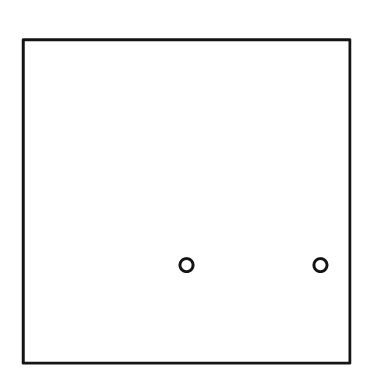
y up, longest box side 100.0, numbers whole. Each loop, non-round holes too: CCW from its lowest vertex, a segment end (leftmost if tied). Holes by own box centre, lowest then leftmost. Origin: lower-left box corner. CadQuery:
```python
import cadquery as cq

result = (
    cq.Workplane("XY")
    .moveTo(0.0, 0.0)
    .lineTo(100.0, 0.0)
    .lineTo(100.0, 99.0)
    .lineTo(0.0, 99.0)
    .close()
    .moveTo(50.0, 30.0)
    .circle(2.0)
    .moveTo(91.0, 30.0)
    .circle(2.0)
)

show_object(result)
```